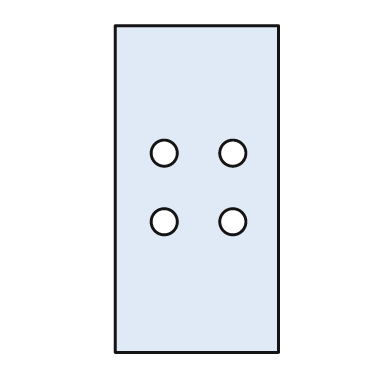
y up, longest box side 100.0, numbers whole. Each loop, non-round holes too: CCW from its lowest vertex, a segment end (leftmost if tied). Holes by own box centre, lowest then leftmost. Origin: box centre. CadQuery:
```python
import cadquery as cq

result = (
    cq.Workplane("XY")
    .moveTo(-25.0, -50.0)
    .lineTo(25.0, -50.0)
    .lineTo(25.0, 50.0)
    .lineTo(-25.0, 50.0)
    .close()
    .moveTo(-10.0, -10.0)
    .circle(4.0)
    .moveTo(11.0, -10.0)
    .circle(4.0)
    .moveTo(-10.0, 11.0)
    .circle(4.0)
    .moveTo(11.0, 11.0)
    .circle(4.0)
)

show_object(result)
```